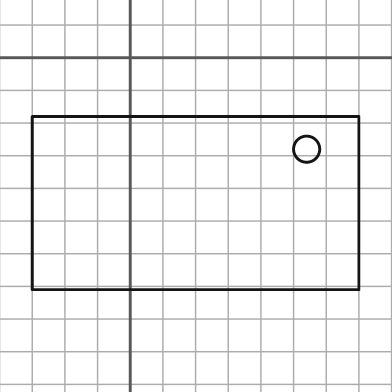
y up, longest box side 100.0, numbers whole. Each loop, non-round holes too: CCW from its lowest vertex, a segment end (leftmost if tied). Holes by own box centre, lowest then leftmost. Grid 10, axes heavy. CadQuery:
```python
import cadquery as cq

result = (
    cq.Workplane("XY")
    .moveTo(-30.0, -71.0)
    .lineTo(70.0, -71.0)
    .lineTo(70.0, -18.0)
    .lineTo(-30.0, -18.0)
    .close()
    .moveTo(54.0, -28.0)
    .circle(4.0)
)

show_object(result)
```